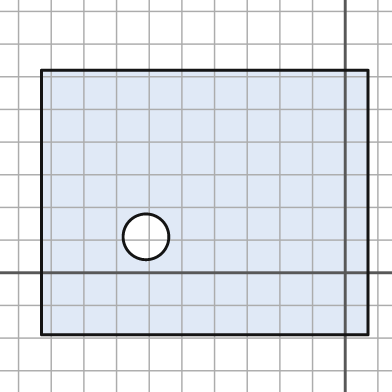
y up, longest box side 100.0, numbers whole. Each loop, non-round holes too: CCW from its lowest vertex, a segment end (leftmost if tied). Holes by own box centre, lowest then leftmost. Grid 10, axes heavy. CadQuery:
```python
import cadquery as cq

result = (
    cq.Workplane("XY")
    .moveTo(-93.0, -19.0)
    .lineTo(7.0, -19.0)
    .lineTo(7.0, 62.0)
    .lineTo(-93.0, 62.0)
    .close()
    .moveTo(-61.0, 11.0)
    .circle(7.0)
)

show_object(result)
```